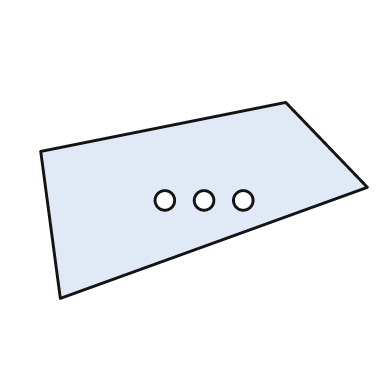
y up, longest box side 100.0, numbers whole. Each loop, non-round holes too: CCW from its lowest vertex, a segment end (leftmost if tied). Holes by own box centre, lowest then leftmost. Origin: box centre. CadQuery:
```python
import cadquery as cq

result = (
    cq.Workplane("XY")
    .moveTo(-44.0, -30.0)
    .lineTo(50.0, 4.0)
    .lineTo(25.0, 30.0)
    .lineTo(-50.0, 15.0)
    .close()
    .moveTo(-12.0, 0.0)
    .circle(3.0)
    .moveTo(0.0, 0.0)
    .circle(3.0)
    .moveTo(12.0, 0.0)
    .circle(3.0)
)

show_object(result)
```